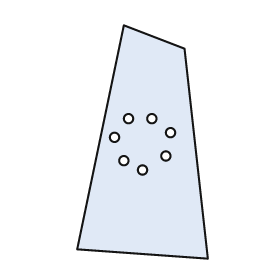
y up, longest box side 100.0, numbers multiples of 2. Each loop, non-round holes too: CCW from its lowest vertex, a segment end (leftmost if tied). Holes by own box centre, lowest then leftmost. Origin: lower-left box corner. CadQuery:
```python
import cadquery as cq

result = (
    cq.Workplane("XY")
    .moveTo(56.0, 0.0)
    .lineTo(46.0, 90.0)
    .lineTo(20.0, 100.0)
    .lineTo(0.0, 4.0)
    .close()
    .moveTo(28.0, 38.0)
    .circle(2.0)
    .moveTo(20.0, 42.0)
    .circle(2.0)
    .moveTo(38.0, 44.0)
    .circle(2.0)
    .moveTo(16.0, 52.0)
    .circle(2.0)
    .moveTo(40.0, 54.0)
    .circle(2.0)
    .moveTo(22.0, 60.0)
    .circle(2.0)
    .moveTo(32.0, 60.0)
    .circle(2.0)
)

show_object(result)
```